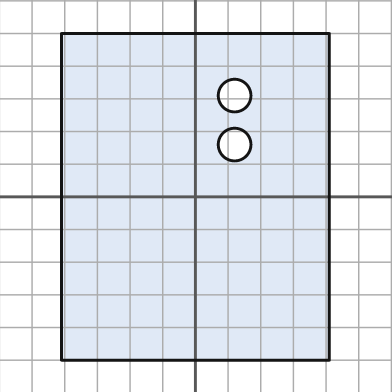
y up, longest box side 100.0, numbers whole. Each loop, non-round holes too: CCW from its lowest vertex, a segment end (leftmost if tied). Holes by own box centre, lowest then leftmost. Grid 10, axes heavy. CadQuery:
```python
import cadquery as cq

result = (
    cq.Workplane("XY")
    .moveTo(-41.0, -50.0)
    .lineTo(41.0, -50.0)
    .lineTo(41.0, 50.0)
    .lineTo(-41.0, 50.0)
    .close()
    .moveTo(12.0, 16.0)
    .circle(5.0)
    .moveTo(12.0, 31.0)
    .circle(5.0)
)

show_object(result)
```